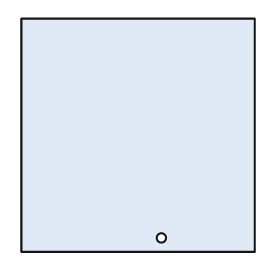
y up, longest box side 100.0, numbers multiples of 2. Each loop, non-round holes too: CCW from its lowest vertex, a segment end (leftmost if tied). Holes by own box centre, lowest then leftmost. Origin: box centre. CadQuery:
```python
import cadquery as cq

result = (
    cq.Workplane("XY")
    .moveTo(-50.0, -50.0)
    .lineTo(50.0, -50.0)
    .lineTo(50.0, 50.0)
    .lineTo(-50.0, 50.0)
    .close()
    .moveTo(10.0, -44.0)
    .circle(2.0)
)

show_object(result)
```